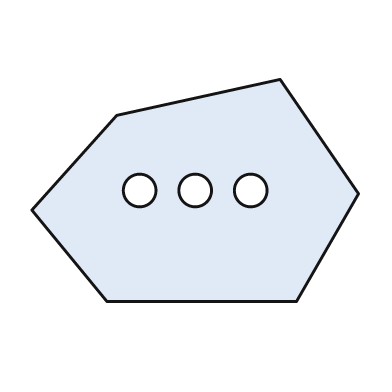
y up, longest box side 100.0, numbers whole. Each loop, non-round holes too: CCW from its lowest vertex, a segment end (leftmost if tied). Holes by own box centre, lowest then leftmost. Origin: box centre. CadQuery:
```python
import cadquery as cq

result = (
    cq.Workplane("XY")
    .moveTo(-27.0, -34.0)
    .lineTo(31.0, -34.0)
    .lineTo(50.0, -1.0)
    .lineTo(26.0, 34.0)
    .lineTo(-24.0, 23.0)
    .lineTo(-50.0, -6.0)
    .close()
    .moveTo(-17.0, 0.0)
    .circle(5.0)
    .moveTo(0.0, 0.0)
    .circle(5.0)
    .moveTo(17.0, 0.0)
    .circle(5.0)
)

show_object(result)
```